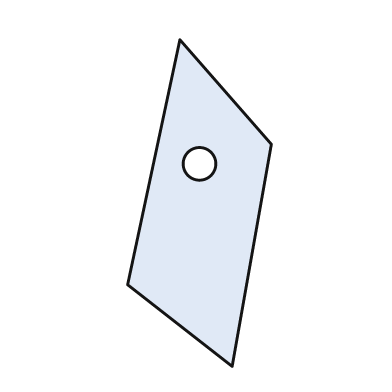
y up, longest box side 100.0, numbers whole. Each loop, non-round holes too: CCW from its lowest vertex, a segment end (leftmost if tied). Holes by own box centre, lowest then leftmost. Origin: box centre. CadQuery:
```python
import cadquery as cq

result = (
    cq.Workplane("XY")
    .moveTo(10.0, -50.0)
    .lineTo(22.0, 18.0)
    .lineTo(-6.0, 50.0)
    .lineTo(-22.0, -25.0)
    .close()
    .moveTo(0.0, 12.0)
    .circle(5.0)
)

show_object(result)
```